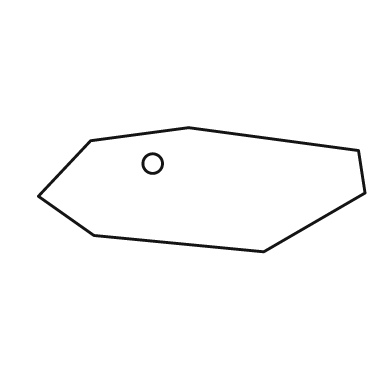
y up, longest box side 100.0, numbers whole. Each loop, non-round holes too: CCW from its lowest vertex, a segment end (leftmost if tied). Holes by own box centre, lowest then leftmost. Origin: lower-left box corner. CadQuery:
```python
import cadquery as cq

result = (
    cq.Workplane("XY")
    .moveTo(69.0, 0.0)
    .lineTo(100.0, 18.0)
    .lineTo(98.0, 31.0)
    .lineTo(46.0, 38.0)
    .lineTo(16.0, 34.0)
    .lineTo(0.0, 17.0)
    .lineTo(17.0, 5.0)
    .close()
    .moveTo(35.0, 27.0)
    .circle(3.0)
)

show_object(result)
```